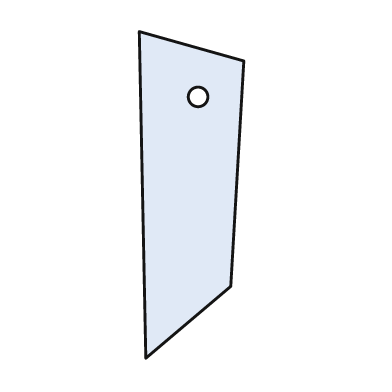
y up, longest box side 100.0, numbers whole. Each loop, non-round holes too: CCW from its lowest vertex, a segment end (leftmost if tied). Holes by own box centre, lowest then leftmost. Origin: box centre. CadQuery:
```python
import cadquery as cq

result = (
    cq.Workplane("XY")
    .moveTo(-14.0, -50.0)
    .lineTo(12.0, -28.0)
    .lineTo(16.0, 41.0)
    .lineTo(-16.0, 50.0)
    .close()
    .moveTo(2.0, 30.0)
    .circle(3.0)
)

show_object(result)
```